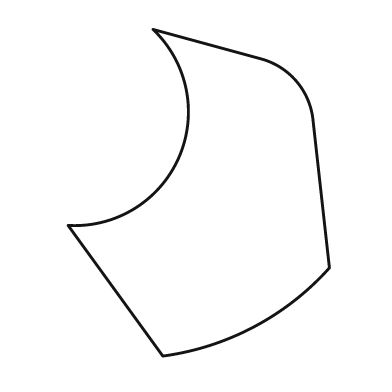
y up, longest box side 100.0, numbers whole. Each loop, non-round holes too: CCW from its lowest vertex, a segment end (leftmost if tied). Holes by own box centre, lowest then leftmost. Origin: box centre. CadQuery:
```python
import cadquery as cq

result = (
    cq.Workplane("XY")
    .moveTo(-11.0, -50.0)
    .threePointArc((17.0, -41.0), (40.0, -23.0))
    .lineTo(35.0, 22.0)
    .threePointArc((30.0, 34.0), (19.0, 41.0))
    .lineTo(-14.0, 50.0)
    .threePointArc((-6.0, 11.0), (-40.0, -10.0))
    .close()
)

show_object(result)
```